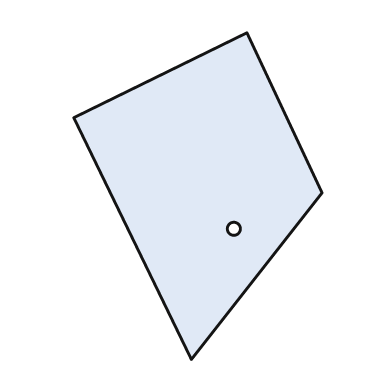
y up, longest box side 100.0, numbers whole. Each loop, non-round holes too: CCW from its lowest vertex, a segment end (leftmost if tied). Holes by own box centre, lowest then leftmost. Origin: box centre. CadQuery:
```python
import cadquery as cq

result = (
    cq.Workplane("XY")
    .moveTo(-2.0, -50.0)
    .lineTo(38.0, 1.0)
    .lineTo(15.0, 50.0)
    .lineTo(-38.0, 24.0)
    .close()
    .moveTo(11.0, -10.0)
    .circle(2.0)
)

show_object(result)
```